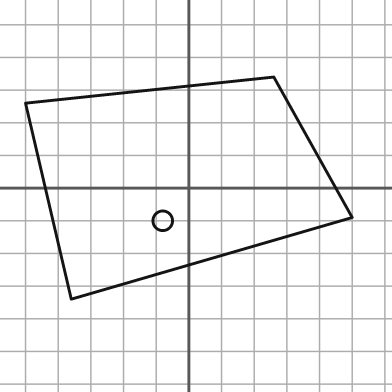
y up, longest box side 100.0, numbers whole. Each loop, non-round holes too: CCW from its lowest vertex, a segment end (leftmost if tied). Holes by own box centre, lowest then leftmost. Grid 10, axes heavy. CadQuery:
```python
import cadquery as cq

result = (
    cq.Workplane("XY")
    .moveTo(-36.0, -34.0)
    .lineTo(50.0, -9.0)
    .lineTo(26.0, 34.0)
    .lineTo(-50.0, 26.0)
    .close()
    .moveTo(-8.0, -10.0)
    .circle(3.0)
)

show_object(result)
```